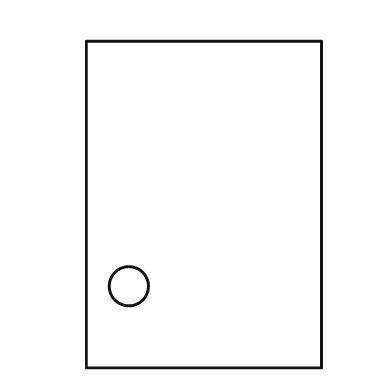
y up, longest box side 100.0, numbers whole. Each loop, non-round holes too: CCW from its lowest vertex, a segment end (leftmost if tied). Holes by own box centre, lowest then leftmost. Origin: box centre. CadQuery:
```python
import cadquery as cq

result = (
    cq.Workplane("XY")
    .moveTo(-36.0, -50.0)
    .lineTo(36.0, -50.0)
    .lineTo(36.0, 50.0)
    .lineTo(-36.0, 50.0)
    .close()
    .moveTo(-23.0, -25.0)
    .circle(6.0)
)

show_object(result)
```